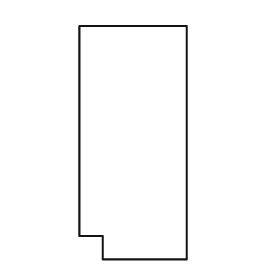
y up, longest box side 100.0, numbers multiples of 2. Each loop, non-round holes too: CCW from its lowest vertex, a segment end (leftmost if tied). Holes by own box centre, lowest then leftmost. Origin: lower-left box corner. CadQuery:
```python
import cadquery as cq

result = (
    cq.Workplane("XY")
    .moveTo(10.0, 0.0)
    .lineTo(46.0, 0.0)
    .lineTo(46.0, 100.0)
    .lineTo(0.0, 100.0)
    .lineTo(0.0, 10.0)
    .lineTo(10.0, 10.0)
    .close()
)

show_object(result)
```